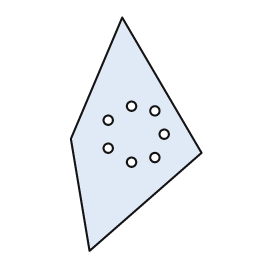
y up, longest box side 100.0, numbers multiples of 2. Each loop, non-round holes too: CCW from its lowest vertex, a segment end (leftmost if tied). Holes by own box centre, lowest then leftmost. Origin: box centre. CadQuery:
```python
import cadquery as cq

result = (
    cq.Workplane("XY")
    .moveTo(-20.0, -50.0)
    .lineTo(28.0, -8.0)
    .lineTo(-6.0, 50.0)
    .lineTo(-28.0, -2.0)
    .close()
    .moveTo(-2.0, -12.0)
    .circle(2.0)
    .moveTo(8.0, -10.0)
    .circle(2.0)
    .moveTo(-12.0, -6.0)
    .circle(2.0)
    .moveTo(12.0, 0.0)
    .circle(2.0)
    .moveTo(-12.0, 6.0)
    .circle(2.0)
    .moveTo(8.0, 10.0)
    .circle(2.0)
    .moveTo(-2.0, 12.0)
    .circle(2.0)
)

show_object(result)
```